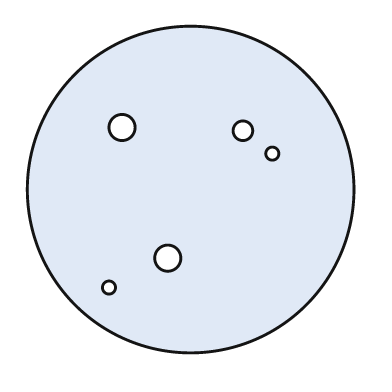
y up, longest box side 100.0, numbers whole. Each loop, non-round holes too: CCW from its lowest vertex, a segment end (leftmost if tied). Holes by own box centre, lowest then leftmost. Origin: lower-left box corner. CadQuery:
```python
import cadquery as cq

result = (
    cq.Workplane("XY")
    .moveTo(50.0, 50.0)
    .circle(50.0)
    .moveTo(25.0, 20.0)
    .circle(2.0)
    .moveTo(43.0, 29.0)
    .circle(4.0)
    .moveTo(75.0, 61.0)
    .circle(2.0)
    .moveTo(66.0, 68.0)
    .circle(3.0)
    .moveTo(29.0, 69.0)
    .circle(4.0)
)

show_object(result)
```